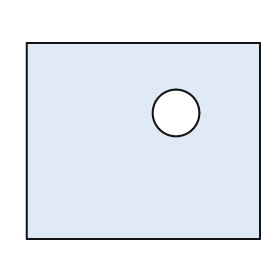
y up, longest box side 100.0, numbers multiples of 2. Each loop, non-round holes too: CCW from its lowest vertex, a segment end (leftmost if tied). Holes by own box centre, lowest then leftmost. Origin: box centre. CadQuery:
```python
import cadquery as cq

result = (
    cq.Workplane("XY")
    .moveTo(-50.0, -42.0)
    .lineTo(50.0, -42.0)
    .lineTo(50.0, 42.0)
    .lineTo(-50.0, 42.0)
    .close()
    .moveTo(14.0, 12.0)
    .circle(10.0)
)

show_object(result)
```